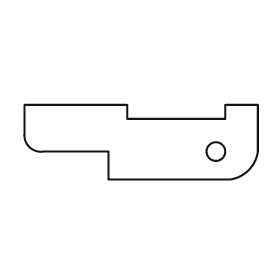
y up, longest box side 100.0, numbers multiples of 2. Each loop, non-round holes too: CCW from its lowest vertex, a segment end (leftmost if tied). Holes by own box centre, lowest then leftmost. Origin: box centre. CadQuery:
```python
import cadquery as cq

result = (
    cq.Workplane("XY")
    .moveTo(-14.0, -16.0)
    .lineTo(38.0, -16.0)
    .threePointArc((46.0, -12.0), (50.0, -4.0))
    .lineTo(50.0, 16.0)
    .lineTo(36.0, 16.0)
    .lineTo(36.0, 10.0)
    .lineTo(-6.0, 10.0)
    .lineTo(-6.0, 16.0)
    .lineTo(-50.0, 16.0)
    .lineTo(-50.0, 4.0)
    .threePointArc((-48.0, -2.0), (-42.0, -4.0))
    .lineTo(-14.0, -4.0)
    .close()
    .moveTo(32.0, -4.0)
    .circle(4.0)
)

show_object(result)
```